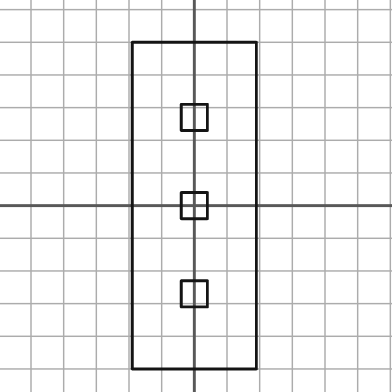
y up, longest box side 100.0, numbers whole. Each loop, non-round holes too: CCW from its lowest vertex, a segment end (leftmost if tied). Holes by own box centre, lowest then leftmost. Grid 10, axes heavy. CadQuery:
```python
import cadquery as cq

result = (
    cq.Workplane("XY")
    .moveTo(-19.0, -50.0)
    .lineTo(19.0, -50.0)
    .lineTo(19.0, 50.0)
    .lineTo(-19.0, 50.0)
    .close()
    .moveTo(-4.0, -31.0)
    .lineTo(4.0, -31.0)
    .lineTo(4.0, -23.0)
    .lineTo(-4.0, -23.0)
    .close()
    .moveTo(-4.0, -4.0)
    .lineTo(4.0, -4.0)
    .lineTo(4.0, 4.0)
    .lineTo(-4.0, 4.0)
    .close()
    .moveTo(-4.0, 23.0)
    .lineTo(4.0, 23.0)
    .lineTo(4.0, 31.0)
    .lineTo(-4.0, 31.0)
    .close()
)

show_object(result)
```